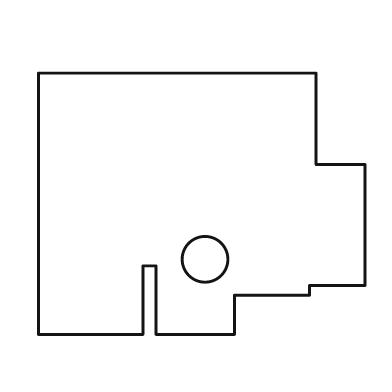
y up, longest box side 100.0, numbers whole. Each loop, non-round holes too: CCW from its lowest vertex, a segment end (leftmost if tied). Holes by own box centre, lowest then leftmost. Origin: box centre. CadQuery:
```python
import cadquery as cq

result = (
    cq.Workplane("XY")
    .moveTo(-50.0, -40.0)
    .lineTo(-18.0, -40.0)
    .lineTo(-18.0, -19.0)
    .lineTo(-14.0, -19.0)
    .lineTo(-14.0, -40.0)
    .lineTo(10.0, -40.0)
    .lineTo(10.0, -28.0)
    .lineTo(33.0, -28.0)
    .lineTo(33.0, -25.0)
    .lineTo(50.0, -25.0)
    .lineTo(50.0, 12.0)
    .lineTo(35.0, 12.0)
    .lineTo(35.0, 40.0)
    .lineTo(-50.0, 40.0)
    .close()
    .moveTo(1.0, -17.0)
    .circle(7.0)
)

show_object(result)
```